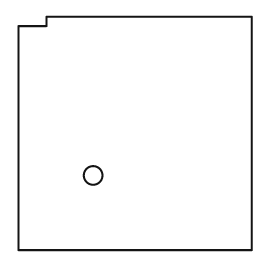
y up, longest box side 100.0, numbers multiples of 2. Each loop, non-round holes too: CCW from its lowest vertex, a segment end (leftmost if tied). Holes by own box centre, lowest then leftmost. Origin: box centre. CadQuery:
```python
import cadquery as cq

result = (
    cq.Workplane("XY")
    .moveTo(-50.0, -50.0)
    .lineTo(50.0, -50.0)
    .lineTo(50.0, 50.0)
    .lineTo(-38.0, 50.0)
    .lineTo(-38.0, 46.0)
    .lineTo(-50.0, 46.0)
    .close()
    .moveTo(-18.0, -18.0)
    .circle(4.0)
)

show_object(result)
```